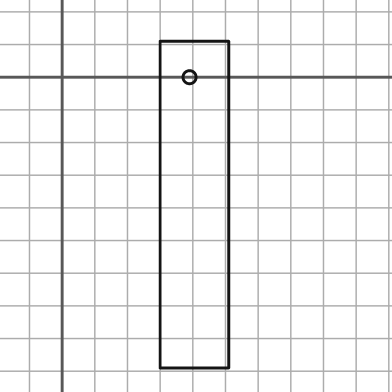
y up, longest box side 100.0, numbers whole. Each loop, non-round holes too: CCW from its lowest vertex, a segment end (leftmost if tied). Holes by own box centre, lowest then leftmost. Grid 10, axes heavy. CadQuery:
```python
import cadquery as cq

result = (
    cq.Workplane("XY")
    .moveTo(30.0, -89.0)
    .lineTo(51.0, -89.0)
    .lineTo(51.0, 11.0)
    .lineTo(30.0, 11.0)
    .close()
    .moveTo(39.0, 0.0)
    .circle(2.0)
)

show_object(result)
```